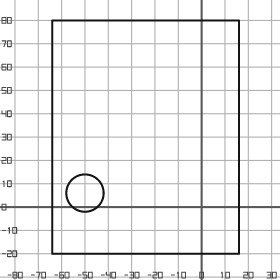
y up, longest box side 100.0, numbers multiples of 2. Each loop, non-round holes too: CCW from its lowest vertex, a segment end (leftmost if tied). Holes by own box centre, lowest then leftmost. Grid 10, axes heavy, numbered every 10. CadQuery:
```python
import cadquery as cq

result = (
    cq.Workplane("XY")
    .moveTo(-64.0, -20.0)
    .lineTo(16.0, -20.0)
    .lineTo(16.0, 80.0)
    .lineTo(-64.0, 80.0)
    .close()
    .moveTo(-50.0, 6.0)
    .circle(8.0)
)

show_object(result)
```